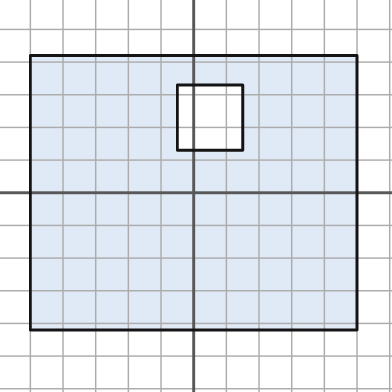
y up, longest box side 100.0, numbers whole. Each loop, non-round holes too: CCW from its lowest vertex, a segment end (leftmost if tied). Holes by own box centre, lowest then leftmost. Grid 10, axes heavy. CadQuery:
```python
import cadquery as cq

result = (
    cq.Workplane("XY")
    .moveTo(-50.0, -42.0)
    .lineTo(50.0, -42.0)
    .lineTo(50.0, 42.0)
    .lineTo(-50.0, 42.0)
    .close()
    .moveTo(-5.0, 13.0)
    .lineTo(15.0, 13.0)
    .lineTo(15.0, 33.0)
    .lineTo(-5.0, 33.0)
    .close()
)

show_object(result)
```